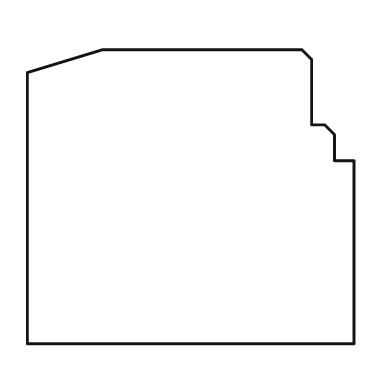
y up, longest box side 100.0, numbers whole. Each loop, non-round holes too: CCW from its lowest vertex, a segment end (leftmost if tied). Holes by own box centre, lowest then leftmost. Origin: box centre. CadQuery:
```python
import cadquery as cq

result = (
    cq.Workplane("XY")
    .moveTo(-50.0, -45.0)
    .lineTo(50.0, -45.0)
    .lineTo(50.0, 11.0)
    .lineTo(44.0, 11.0)
    .lineTo(44.0, 19.0)
    .lineTo(41.0, 22.0)
    .lineTo(37.0, 22.0)
    .lineTo(37.0, 42.0)
    .lineTo(34.0, 45.0)
    .lineTo(-27.0, 45.0)
    .lineTo(-50.0, 38.0)
    .close()
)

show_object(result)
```